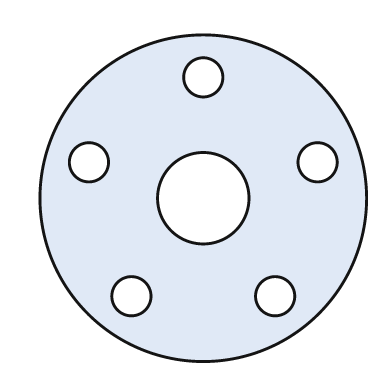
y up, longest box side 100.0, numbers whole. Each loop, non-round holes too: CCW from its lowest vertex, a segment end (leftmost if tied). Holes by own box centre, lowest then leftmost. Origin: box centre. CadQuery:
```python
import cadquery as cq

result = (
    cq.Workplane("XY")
    .moveTo(0.0, 0.0)
    .circle(50.0)
    .moveTo(-22.0, -30.0)
    .circle(6.0)
    .moveTo(22.0, -30.0)
    .circle(6.0)
    .moveTo(0.0, 0.0)
    .circle(14.0)
    .moveTo(-35.0, 11.0)
    .circle(6.0)
    .moveTo(35.0, 11.0)
    .circle(6.0)
    .moveTo(0.0, 37.0)
    .circle(6.0)
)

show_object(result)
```